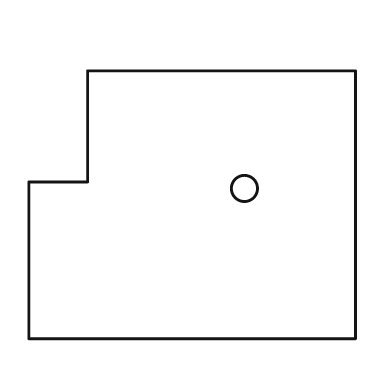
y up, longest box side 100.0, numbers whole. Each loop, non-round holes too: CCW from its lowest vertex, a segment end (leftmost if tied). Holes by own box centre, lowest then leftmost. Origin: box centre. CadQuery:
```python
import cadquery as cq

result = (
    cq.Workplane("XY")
    .moveTo(-50.0, -41.0)
    .lineTo(50.0, -41.0)
    .lineTo(50.0, 41.0)
    .lineTo(-32.0, 41.0)
    .lineTo(-32.0, 7.0)
    .lineTo(-50.0, 7.0)
    .close()
    .moveTo(16.0, 5.0)
    .circle(4.0)
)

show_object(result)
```